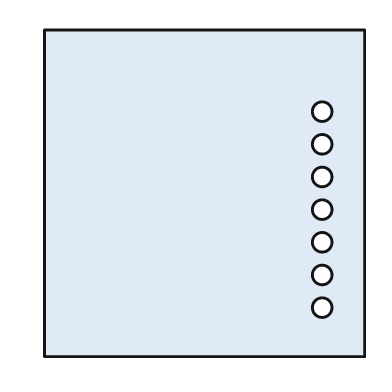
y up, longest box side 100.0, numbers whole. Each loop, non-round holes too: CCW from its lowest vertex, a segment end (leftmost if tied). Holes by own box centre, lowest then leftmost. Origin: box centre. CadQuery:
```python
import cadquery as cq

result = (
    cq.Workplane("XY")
    .moveTo(-49.0, -50.0)
    .lineTo(49.0, -50.0)
    .lineTo(49.0, 50.0)
    .lineTo(-49.0, 50.0)
    .close()
    .moveTo(36.0, -35.0)
    .circle(3.0)
    .moveTo(36.0, -25.0)
    .circle(3.0)
    .moveTo(36.0, -15.0)
    .circle(3.0)
    .moveTo(36.0, -5.0)
    .circle(3.0)
    .moveTo(36.0, 5.0)
    .circle(3.0)
    .moveTo(36.0, 15.0)
    .circle(3.0)
    .moveTo(36.0, 25.0)
    .circle(3.0)
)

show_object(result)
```